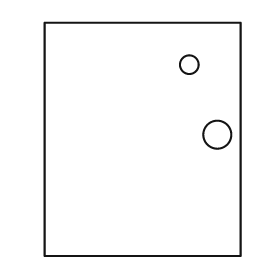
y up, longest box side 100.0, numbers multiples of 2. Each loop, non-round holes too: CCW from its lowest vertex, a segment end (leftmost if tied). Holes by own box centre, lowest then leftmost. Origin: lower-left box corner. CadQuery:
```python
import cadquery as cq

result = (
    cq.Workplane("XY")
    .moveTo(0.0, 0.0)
    .lineTo(84.0, 0.0)
    .lineTo(84.0, 100.0)
    .lineTo(0.0, 100.0)
    .close()
    .moveTo(74.0, 52.0)
    .circle(6.0)
    .moveTo(62.0, 82.0)
    .circle(4.0)
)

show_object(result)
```